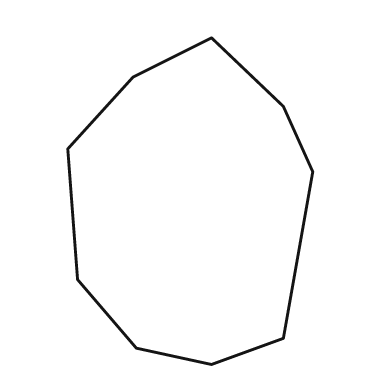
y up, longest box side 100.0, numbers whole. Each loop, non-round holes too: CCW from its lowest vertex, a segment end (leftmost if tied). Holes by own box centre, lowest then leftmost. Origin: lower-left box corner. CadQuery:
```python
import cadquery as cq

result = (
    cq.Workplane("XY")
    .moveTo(44.0, 0.0)
    .lineTo(66.0, 8.0)
    .lineTo(75.0, 59.0)
    .lineTo(66.0, 79.0)
    .lineTo(44.0, 100.0)
    .lineTo(20.0, 88.0)
    .lineTo(0.0, 66.0)
    .lineTo(3.0, 26.0)
    .lineTo(21.0, 5.0)
    .close()
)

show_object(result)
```